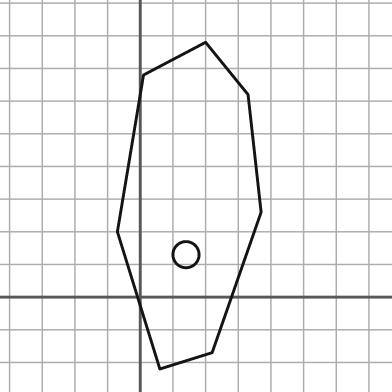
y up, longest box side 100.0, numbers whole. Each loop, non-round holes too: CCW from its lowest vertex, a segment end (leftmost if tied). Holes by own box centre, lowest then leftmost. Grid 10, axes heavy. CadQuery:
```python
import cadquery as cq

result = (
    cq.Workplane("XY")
    .moveTo(6.0, -22.0)
    .lineTo(22.0, -17.0)
    .lineTo(37.0, 26.0)
    .lineTo(33.0, 62.0)
    .lineTo(20.0, 78.0)
    .lineTo(1.0, 68.0)
    .lineTo(-7.0, 20.0)
    .close()
    .moveTo(14.0, 13.0)
    .circle(4.0)
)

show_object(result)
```